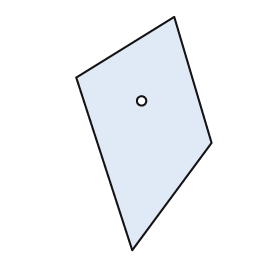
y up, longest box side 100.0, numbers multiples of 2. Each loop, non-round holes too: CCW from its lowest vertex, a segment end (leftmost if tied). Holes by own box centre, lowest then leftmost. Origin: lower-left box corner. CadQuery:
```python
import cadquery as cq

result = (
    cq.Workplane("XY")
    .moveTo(24.0, 0.0)
    .lineTo(58.0, 46.0)
    .lineTo(42.0, 100.0)
    .lineTo(0.0, 74.0)
    .close()
    .moveTo(28.0, 64.0)
    .circle(2.0)
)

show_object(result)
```